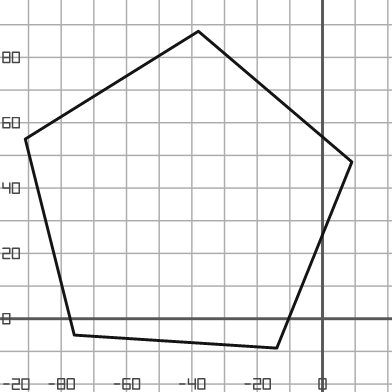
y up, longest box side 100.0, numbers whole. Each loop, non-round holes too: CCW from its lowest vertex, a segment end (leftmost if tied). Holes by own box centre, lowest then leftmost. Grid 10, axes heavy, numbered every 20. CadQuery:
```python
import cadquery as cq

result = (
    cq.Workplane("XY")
    .moveTo(-14.0, -9.0)
    .lineTo(9.0, 48.0)
    .lineTo(-38.0, 88.0)
    .lineTo(-91.0, 55.0)
    .lineTo(-76.0, -5.0)
    .close()
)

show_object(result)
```